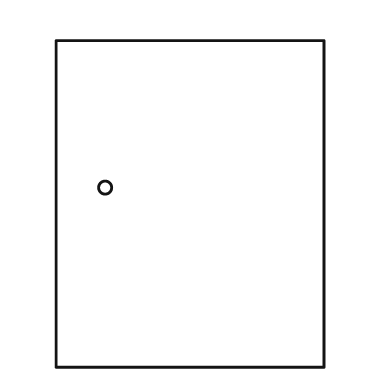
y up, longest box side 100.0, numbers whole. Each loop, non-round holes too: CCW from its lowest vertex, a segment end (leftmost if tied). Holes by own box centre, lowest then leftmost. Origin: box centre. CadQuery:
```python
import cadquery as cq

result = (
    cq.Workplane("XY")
    .moveTo(-41.0, -50.0)
    .lineTo(41.0, -50.0)
    .lineTo(41.0, 50.0)
    .lineTo(-41.0, 50.0)
    .close()
    .moveTo(-26.0, 5.0)
    .circle(2.0)
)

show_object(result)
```